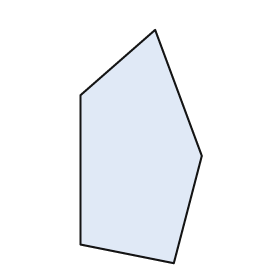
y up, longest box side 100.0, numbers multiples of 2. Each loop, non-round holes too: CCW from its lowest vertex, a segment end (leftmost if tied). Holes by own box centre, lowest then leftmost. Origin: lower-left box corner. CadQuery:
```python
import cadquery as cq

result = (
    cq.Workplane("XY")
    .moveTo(40.0, 0.0)
    .lineTo(52.0, 46.0)
    .lineTo(32.0, 100.0)
    .lineTo(0.0, 72.0)
    .lineTo(0.0, 8.0)
    .close()
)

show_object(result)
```